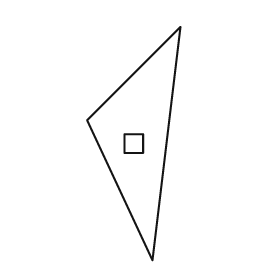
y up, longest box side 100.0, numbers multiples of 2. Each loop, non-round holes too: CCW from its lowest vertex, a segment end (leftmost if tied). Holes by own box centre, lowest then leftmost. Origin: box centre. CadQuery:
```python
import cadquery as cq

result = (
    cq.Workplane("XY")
    .moveTo(8.0, -50.0)
    .lineTo(20.0, 50.0)
    .lineTo(-20.0, 10.0)
    .close()
    .moveTo(-4.0, -4.0)
    .lineTo(4.0, -4.0)
    .lineTo(4.0, 4.0)
    .lineTo(-4.0, 4.0)
    .close()
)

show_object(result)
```